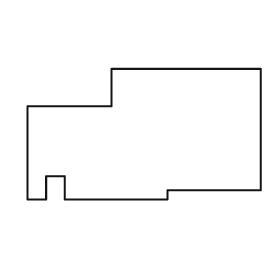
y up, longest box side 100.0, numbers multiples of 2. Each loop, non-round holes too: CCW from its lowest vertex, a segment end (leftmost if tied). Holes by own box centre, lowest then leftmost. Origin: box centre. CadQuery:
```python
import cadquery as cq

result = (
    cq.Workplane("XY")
    .moveTo(-50.0, -28.0)
    .lineTo(-42.0, -28.0)
    .lineTo(-42.0, -18.0)
    .lineTo(-34.0, -18.0)
    .lineTo(-34.0, -28.0)
    .lineTo(10.0, -28.0)
    .lineTo(10.0, -24.0)
    .lineTo(50.0, -24.0)
    .lineTo(50.0, 28.0)
    .lineTo(-14.0, 28.0)
    .lineTo(-14.0, 12.0)
    .lineTo(-50.0, 12.0)
    .close()
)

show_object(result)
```